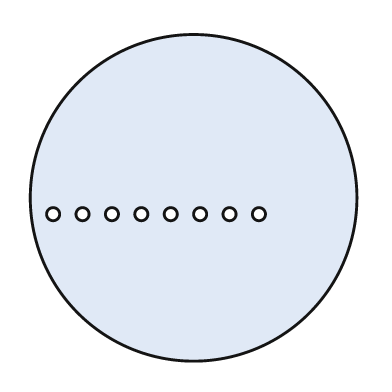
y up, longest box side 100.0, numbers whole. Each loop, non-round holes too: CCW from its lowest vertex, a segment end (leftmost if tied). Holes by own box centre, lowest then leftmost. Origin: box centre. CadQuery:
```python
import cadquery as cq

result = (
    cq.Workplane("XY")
    .moveTo(0.0, 0.0)
    .circle(50.0)
    .moveTo(-43.0, -5.0)
    .circle(2.0)
    .moveTo(-34.0, -5.0)
    .circle(2.0)
    .moveTo(-25.0, -5.0)
    .circle(2.0)
    .moveTo(-16.0, -5.0)
    .circle(2.0)
    .moveTo(-7.0, -5.0)
    .circle(2.0)
    .moveTo(2.0, -5.0)
    .circle(2.0)
    .moveTo(11.0, -5.0)
    .circle(2.0)
    .moveTo(20.0, -5.0)
    .circle(2.0)
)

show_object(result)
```